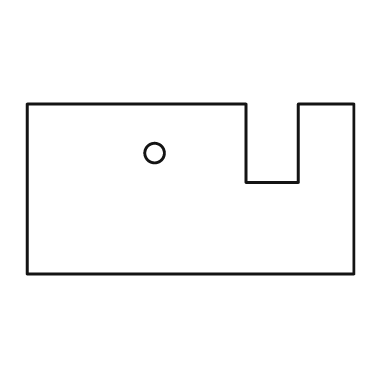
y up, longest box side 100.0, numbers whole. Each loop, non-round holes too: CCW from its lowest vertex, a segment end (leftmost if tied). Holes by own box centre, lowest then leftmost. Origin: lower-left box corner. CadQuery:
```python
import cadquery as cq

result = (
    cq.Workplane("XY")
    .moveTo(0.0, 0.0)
    .lineTo(100.0, 0.0)
    .lineTo(100.0, 52.0)
    .lineTo(83.0, 52.0)
    .lineTo(83.0, 28.0)
    .lineTo(67.0, 28.0)
    .lineTo(67.0, 52.0)
    .lineTo(0.0, 52.0)
    .close()
    .moveTo(39.0, 37.0)
    .circle(3.0)
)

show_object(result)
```